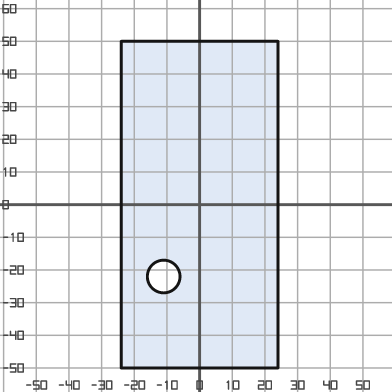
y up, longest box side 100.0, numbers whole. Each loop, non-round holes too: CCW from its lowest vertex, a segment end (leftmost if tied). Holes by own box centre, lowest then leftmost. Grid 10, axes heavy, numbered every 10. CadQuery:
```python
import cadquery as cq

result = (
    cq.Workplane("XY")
    .moveTo(-24.0, -50.0)
    .lineTo(24.0, -50.0)
    .lineTo(24.0, 50.0)
    .lineTo(-24.0, 50.0)
    .close()
    .moveTo(-11.0, -22.0)
    .circle(5.0)
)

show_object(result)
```